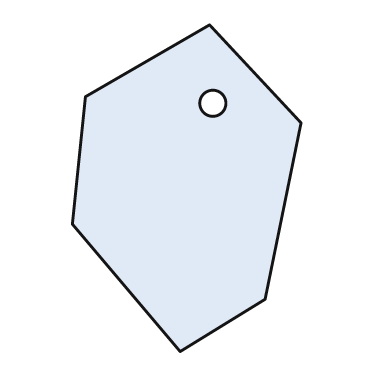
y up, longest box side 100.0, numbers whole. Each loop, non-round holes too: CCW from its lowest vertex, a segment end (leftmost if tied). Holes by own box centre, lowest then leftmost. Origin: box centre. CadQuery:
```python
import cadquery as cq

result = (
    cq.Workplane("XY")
    .moveTo(-2.0, -50.0)
    .lineTo(24.0, -34.0)
    .lineTo(35.0, 20.0)
    .lineTo(7.0, 50.0)
    .lineTo(-31.0, 28.0)
    .lineTo(-35.0, -11.0)
    .close()
    .moveTo(8.0, 26.0)
    .circle(4.0)
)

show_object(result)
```